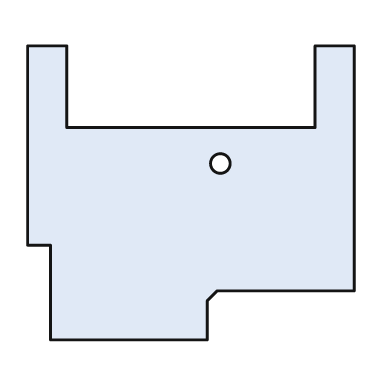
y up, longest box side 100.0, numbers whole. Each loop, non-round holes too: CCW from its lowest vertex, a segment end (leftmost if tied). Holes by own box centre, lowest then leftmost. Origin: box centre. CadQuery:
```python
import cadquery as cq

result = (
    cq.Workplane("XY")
    .moveTo(-43.0, -45.0)
    .lineTo(5.0, -45.0)
    .lineTo(5.0, -33.0)
    .lineTo(8.0, -30.0)
    .lineTo(50.0, -30.0)
    .lineTo(50.0, 45.0)
    .lineTo(38.0, 45.0)
    .lineTo(38.0, 20.0)
    .lineTo(-38.0, 20.0)
    .lineTo(-38.0, 45.0)
    .lineTo(-50.0, 45.0)
    .lineTo(-50.0, -16.0)
    .lineTo(-43.0, -16.0)
    .close()
    .moveTo(9.0, 9.0)
    .circle(3.0)
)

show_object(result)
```